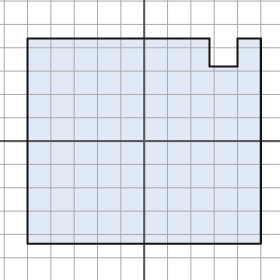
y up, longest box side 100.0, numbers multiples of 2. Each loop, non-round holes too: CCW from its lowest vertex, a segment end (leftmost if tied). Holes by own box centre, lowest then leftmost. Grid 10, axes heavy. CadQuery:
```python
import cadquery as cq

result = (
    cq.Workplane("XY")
    .moveTo(-50.0, -44.0)
    .lineTo(50.0, -44.0)
    .lineTo(50.0, 44.0)
    .lineTo(40.0, 44.0)
    .lineTo(40.0, 32.0)
    .lineTo(28.0, 32.0)
    .lineTo(28.0, 44.0)
    .lineTo(-50.0, 44.0)
    .close()
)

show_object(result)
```